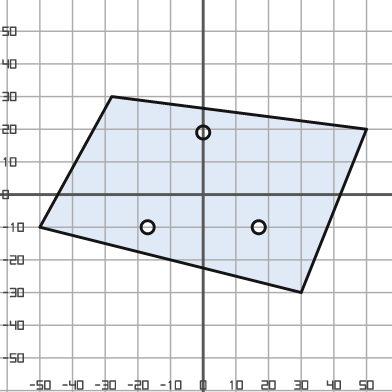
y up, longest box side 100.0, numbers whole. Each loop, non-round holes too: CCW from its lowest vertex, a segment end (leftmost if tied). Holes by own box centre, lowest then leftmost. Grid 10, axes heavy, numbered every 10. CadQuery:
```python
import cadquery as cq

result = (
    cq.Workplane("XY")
    .moveTo(30.0, -30.0)
    .lineTo(50.0, 20.0)
    .lineTo(-28.0, 30.0)
    .lineTo(-50.0, -10.0)
    .close()
    .moveTo(-17.0, -10.0)
    .circle(2.0)
    .moveTo(17.0, -10.0)
    .circle(2.0)
    .moveTo(0.0, 19.0)
    .circle(2.0)
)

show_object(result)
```